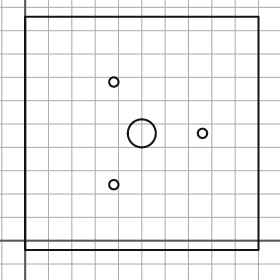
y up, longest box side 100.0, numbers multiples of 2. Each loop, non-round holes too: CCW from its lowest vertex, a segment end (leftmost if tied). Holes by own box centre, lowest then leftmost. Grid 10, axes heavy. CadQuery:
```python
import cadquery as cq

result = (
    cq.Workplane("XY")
    .moveTo(0.0, -4.0)
    .lineTo(100.0, -4.0)
    .lineTo(100.0, 96.0)
    .lineTo(0.0, 96.0)
    .close()
    .moveTo(38.0, 24.0)
    .circle(2.0)
    .moveTo(50.0, 46.0)
    .circle(6.0)
    .moveTo(76.0, 46.0)
    .circle(2.0)
    .moveTo(38.0, 68.0)
    .circle(2.0)
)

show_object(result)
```